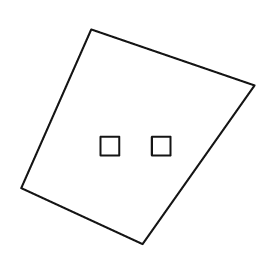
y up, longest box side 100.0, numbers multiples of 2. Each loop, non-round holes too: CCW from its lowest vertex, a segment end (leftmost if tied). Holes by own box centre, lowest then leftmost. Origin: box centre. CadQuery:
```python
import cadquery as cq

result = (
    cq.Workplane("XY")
    .moveTo(2.0, -46.0)
    .lineTo(50.0, 22.0)
    .lineTo(-20.0, 46.0)
    .lineTo(-50.0, -22.0)
    .close()
    .moveTo(-16.0, -8.0)
    .lineTo(-8.0, -8.0)
    .lineTo(-8.0, 0.0)
    .lineTo(-16.0, 0.0)
    .close()
    .moveTo(6.0, -8.0)
    .lineTo(14.0, -8.0)
    .lineTo(14.0, 0.0)
    .lineTo(6.0, 0.0)
    .close()
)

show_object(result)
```